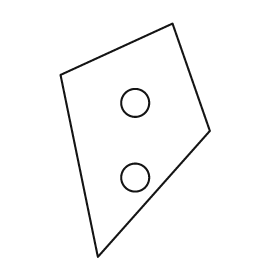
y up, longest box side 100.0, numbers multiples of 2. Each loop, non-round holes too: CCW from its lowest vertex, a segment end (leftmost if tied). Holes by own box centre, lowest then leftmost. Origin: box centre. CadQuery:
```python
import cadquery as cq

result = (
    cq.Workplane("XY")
    .moveTo(-16.0, -50.0)
    .lineTo(32.0, 4.0)
    .lineTo(16.0, 50.0)
    .lineTo(-32.0, 28.0)
    .close()
    .moveTo(0.0, -16.0)
    .circle(6.0)
    .moveTo(0.0, 16.0)
    .circle(6.0)
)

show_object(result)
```